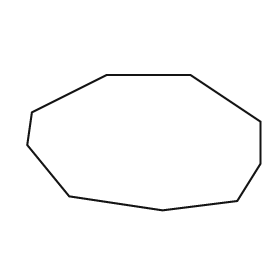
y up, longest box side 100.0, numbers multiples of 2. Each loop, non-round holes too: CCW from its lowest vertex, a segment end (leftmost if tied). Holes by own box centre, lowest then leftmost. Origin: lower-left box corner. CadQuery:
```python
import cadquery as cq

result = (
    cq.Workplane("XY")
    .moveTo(58.0, 0.0)
    .lineTo(90.0, 4.0)
    .lineTo(100.0, 20.0)
    .lineTo(100.0, 38.0)
    .lineTo(70.0, 58.0)
    .lineTo(34.0, 58.0)
    .lineTo(2.0, 42.0)
    .lineTo(0.0, 28.0)
    .lineTo(18.0, 6.0)
    .close()
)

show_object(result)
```